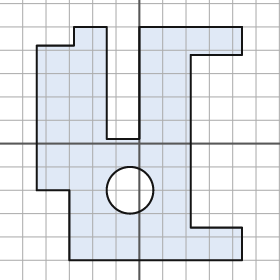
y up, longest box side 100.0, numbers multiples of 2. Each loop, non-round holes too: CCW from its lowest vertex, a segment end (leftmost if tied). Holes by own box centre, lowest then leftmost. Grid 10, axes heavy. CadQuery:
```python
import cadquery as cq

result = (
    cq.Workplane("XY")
    .moveTo(-30.0, -50.0)
    .lineTo(44.0, -50.0)
    .lineTo(44.0, -36.0)
    .lineTo(22.0, -36.0)
    .lineTo(22.0, 38.0)
    .lineTo(44.0, 38.0)
    .lineTo(44.0, 50.0)
    .lineTo(0.0, 50.0)
    .lineTo(0.0, 2.0)
    .lineTo(-14.0, 2.0)
    .lineTo(-14.0, 50.0)
    .lineTo(-28.0, 50.0)
    .lineTo(-28.0, 42.0)
    .lineTo(-44.0, 42.0)
    .lineTo(-44.0, -20.0)
    .lineTo(-30.0, -20.0)
    .close()
    .moveTo(-4.0, -20.0)
    .circle(10.0)
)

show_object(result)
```